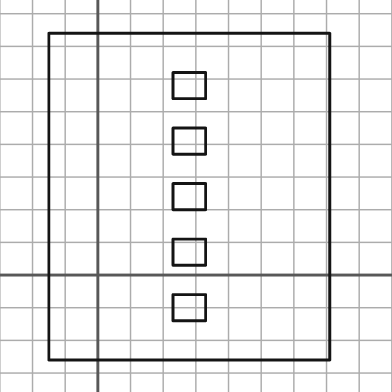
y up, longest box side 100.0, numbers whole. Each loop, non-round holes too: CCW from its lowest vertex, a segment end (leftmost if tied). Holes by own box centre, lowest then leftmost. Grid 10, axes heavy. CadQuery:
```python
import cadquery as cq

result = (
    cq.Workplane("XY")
    .moveTo(-15.0, -26.0)
    .lineTo(71.0, -26.0)
    .lineTo(71.0, 74.0)
    .lineTo(-15.0, 74.0)
    .close()
    .moveTo(23.0, -14.0)
    .lineTo(33.0, -14.0)
    .lineTo(33.0, -6.0)
    .lineTo(23.0, -6.0)
    .close()
    .moveTo(23.0, 3.0)
    .lineTo(33.0, 3.0)
    .lineTo(33.0, 11.0)
    .lineTo(23.0, 11.0)
    .close()
    .moveTo(23.0, 20.0)
    .lineTo(33.0, 20.0)
    .lineTo(33.0, 28.0)
    .lineTo(23.0, 28.0)
    .close()
    .moveTo(23.0, 37.0)
    .lineTo(33.0, 37.0)
    .lineTo(33.0, 45.0)
    .lineTo(23.0, 45.0)
    .close()
    .moveTo(23.0, 54.0)
    .lineTo(33.0, 54.0)
    .lineTo(33.0, 62.0)
    .lineTo(23.0, 62.0)
    .close()
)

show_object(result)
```